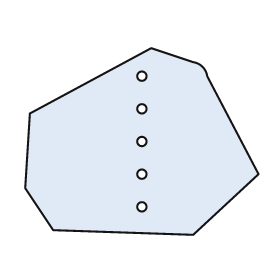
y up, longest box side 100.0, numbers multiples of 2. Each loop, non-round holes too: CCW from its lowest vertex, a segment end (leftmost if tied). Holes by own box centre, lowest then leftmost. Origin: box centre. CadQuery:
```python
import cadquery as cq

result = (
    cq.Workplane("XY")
    .moveTo(22.0, -40.0)
    .lineTo(50.0, -14.0)
    .lineTo(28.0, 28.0)
    .threePointArc((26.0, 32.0), (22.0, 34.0))
    .lineTo(4.0, 40.0)
    .lineTo(-48.0, 12.0)
    .lineTo(-50.0, -20.0)
    .lineTo(-38.0, -38.0)
    .close()
    .moveTo(0.0, -28.0)
    .circle(2.0)
    .moveTo(0.0, -14.0)
    .circle(2.0)
    .moveTo(0.0, 0.0)
    .circle(2.0)
    .moveTo(0.0, 14.0)
    .circle(2.0)
    .moveTo(0.0, 28.0)
    .circle(2.0)
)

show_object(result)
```